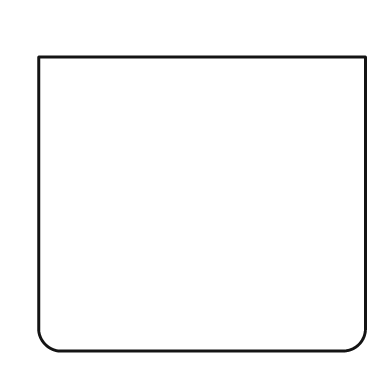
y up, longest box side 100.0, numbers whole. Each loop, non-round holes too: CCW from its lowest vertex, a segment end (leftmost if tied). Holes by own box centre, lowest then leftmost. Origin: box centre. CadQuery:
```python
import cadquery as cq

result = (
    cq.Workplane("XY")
    .moveTo(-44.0, -45.0)
    .lineTo(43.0, -45.0)
    .threePointArc((48.0, -43.0), (50.0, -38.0))
    .lineTo(50.0, 45.0)
    .lineTo(-50.0, 45.0)
    .lineTo(-50.0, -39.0)
    .threePointArc((-48.0, -43.0), (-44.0, -45.0))
    .close()
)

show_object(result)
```